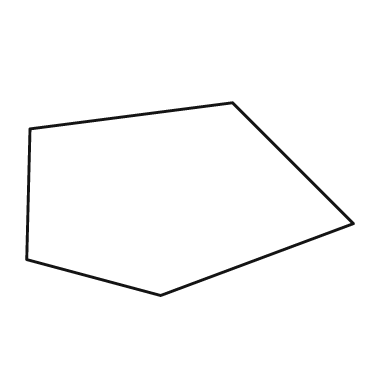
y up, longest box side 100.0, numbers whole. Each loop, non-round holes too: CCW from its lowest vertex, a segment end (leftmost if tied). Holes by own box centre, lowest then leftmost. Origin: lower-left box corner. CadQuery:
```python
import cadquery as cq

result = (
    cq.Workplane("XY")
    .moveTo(41.0, 0.0)
    .lineTo(100.0, 22.0)
    .lineTo(63.0, 59.0)
    .lineTo(1.0, 51.0)
    .lineTo(0.0, 11.0)
    .close()
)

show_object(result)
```